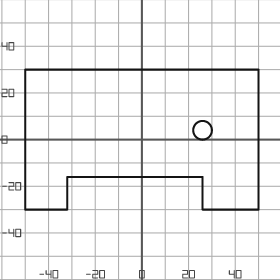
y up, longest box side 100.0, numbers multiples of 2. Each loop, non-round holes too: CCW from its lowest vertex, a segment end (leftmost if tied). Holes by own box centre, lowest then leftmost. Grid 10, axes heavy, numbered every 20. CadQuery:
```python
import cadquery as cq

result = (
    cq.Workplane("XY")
    .moveTo(-50.0, -30.0)
    .lineTo(-32.0, -30.0)
    .lineTo(-32.0, -16.0)
    .lineTo(26.0, -16.0)
    .lineTo(26.0, -30.0)
    .lineTo(50.0, -30.0)
    .lineTo(50.0, 30.0)
    .lineTo(-50.0, 30.0)
    .close()
    .moveTo(26.0, 4.0)
    .circle(4.0)
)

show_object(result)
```